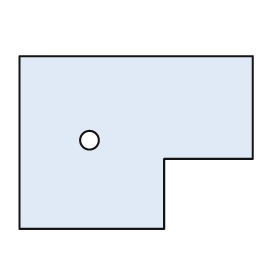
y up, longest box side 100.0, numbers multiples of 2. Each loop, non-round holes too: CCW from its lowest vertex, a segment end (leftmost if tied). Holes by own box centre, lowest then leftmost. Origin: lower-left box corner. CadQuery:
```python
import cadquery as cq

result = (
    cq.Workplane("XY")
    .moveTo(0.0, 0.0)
    .lineTo(62.0, 0.0)
    .lineTo(62.0, 30.0)
    .lineTo(100.0, 30.0)
    .lineTo(100.0, 74.0)
    .lineTo(0.0, 74.0)
    .close()
    .moveTo(30.0, 38.0)
    .circle(4.0)
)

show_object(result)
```